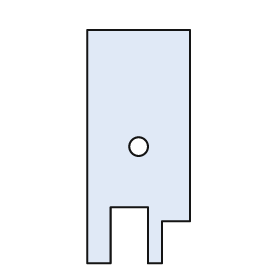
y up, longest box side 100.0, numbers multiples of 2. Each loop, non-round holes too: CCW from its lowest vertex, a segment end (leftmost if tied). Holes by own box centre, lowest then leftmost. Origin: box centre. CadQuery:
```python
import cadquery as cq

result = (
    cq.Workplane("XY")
    .moveTo(-22.0, -50.0)
    .lineTo(-12.0, -50.0)
    .lineTo(-12.0, -26.0)
    .lineTo(4.0, -26.0)
    .lineTo(4.0, -50.0)
    .lineTo(10.0, -50.0)
    .lineTo(10.0, -32.0)
    .lineTo(22.0, -32.0)
    .lineTo(22.0, 50.0)
    .lineTo(-22.0, 50.0)
    .close()
    .moveTo(0.0, 0.0)
    .circle(4.0)
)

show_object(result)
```